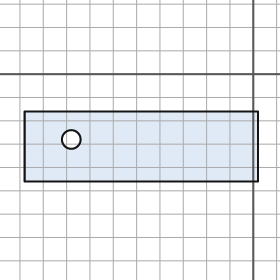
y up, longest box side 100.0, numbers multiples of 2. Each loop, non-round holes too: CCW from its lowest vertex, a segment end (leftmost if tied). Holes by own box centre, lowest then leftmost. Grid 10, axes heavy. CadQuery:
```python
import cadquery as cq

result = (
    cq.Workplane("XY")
    .moveTo(-98.0, -46.0)
    .lineTo(2.0, -46.0)
    .lineTo(2.0, -16.0)
    .lineTo(-98.0, -16.0)
    .close()
    .moveTo(-78.0, -28.0)
    .circle(4.0)
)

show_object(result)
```